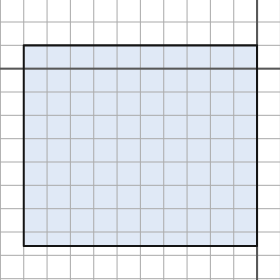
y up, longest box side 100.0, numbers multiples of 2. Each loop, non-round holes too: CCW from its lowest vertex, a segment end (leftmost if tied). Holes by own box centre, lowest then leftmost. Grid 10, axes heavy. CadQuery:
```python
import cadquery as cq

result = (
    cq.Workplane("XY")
    .moveTo(-100.0, -76.0)
    .lineTo(0.0, -76.0)
    .lineTo(0.0, 10.0)
    .lineTo(-100.0, 10.0)
    .close()
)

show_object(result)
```